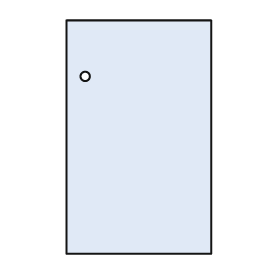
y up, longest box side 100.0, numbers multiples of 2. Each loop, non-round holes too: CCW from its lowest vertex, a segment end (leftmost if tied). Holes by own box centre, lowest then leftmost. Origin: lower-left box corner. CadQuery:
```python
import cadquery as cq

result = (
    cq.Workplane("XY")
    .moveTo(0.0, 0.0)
    .lineTo(62.0, 0.0)
    .lineTo(62.0, 100.0)
    .lineTo(0.0, 100.0)
    .close()
    .moveTo(8.0, 76.0)
    .circle(2.0)
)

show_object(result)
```